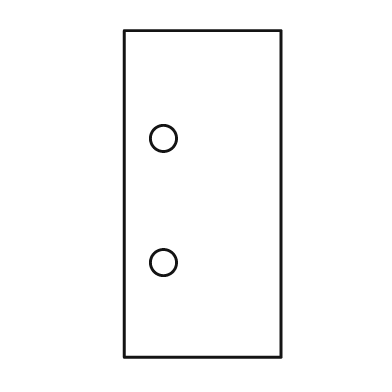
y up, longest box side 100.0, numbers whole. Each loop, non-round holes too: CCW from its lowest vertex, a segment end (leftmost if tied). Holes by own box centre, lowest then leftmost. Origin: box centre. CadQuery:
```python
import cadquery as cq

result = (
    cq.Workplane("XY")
    .moveTo(-24.0, -50.0)
    .lineTo(24.0, -50.0)
    .lineTo(24.0, 50.0)
    .lineTo(-24.0, 50.0)
    .close()
    .moveTo(-12.0, -21.0)
    .circle(4.0)
    .moveTo(-12.0, 17.0)
    .circle(4.0)
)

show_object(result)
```